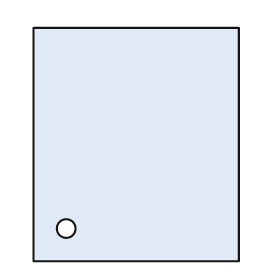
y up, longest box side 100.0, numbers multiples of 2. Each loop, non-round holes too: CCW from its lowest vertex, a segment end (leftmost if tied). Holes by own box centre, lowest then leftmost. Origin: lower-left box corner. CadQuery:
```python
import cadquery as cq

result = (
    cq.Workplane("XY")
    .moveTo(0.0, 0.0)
    .lineTo(88.0, 0.0)
    .lineTo(88.0, 100.0)
    .lineTo(0.0, 100.0)
    .close()
    .moveTo(14.0, 14.0)
    .circle(4.0)
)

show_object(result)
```